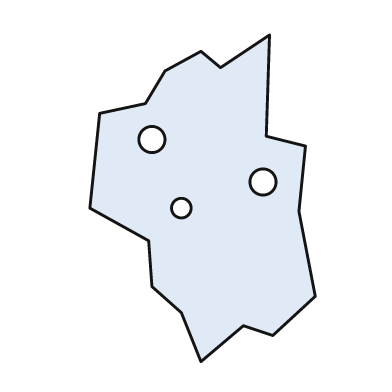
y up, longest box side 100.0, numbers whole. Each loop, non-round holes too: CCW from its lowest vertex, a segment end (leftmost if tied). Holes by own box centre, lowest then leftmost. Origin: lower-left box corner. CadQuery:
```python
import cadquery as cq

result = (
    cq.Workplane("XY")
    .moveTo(34.0, 0.0)
    .lineTo(47.0, 11.0)
    .lineTo(56.0, 8.0)
    .lineTo(69.0, 20.0)
    .lineTo(64.0, 46.0)
    .lineTo(66.0, 66.0)
    .lineTo(54.0, 69.0)
    .lineTo(55.0, 100.0)
    .lineTo(40.0, 90.0)
    .lineTo(34.0, 95.0)
    .lineTo(23.0, 89.0)
    .lineTo(17.0, 79.0)
    .lineTo(3.0, 76.0)
    .lineTo(0.0, 47.0)
    .lineTo(18.0, 37.0)
    .lineTo(19.0, 23.0)
    .lineTo(28.0, 15.0)
    .close()
    .moveTo(28.0, 47.0)
    .circle(3.0)
    .moveTo(53.0, 55.0)
    .circle(4.0)
    .moveTo(19.0, 68.0)
    .circle(4.0)
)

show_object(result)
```